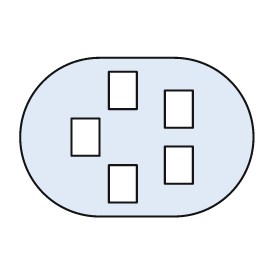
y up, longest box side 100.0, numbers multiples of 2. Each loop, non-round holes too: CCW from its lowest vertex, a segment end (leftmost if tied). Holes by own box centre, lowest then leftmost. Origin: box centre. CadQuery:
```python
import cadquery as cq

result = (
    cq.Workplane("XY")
    .moveTo(-16.0, -34.0)
    .lineTo(16.0, -34.0)
    .threePointArc((50.0, 0.0), (16.0, 34.0))
    .lineTo(-16.0, 34.0)
    .threePointArc((-50.0, 0.0), (-16.0, -34.0))
    .close()
    .moveTo(-12.0, -28.0)
    .lineTo(0.0, -28.0)
    .lineTo(0.0, -12.0)
    .lineTo(-12.0, -12.0)
    .close()
    .moveTo(12.0, -20.0)
    .lineTo(24.0, -20.0)
    .lineTo(24.0, -4.0)
    .lineTo(12.0, -4.0)
    .close()
    .moveTo(-28.0, -8.0)
    .lineTo(-16.0, -8.0)
    .lineTo(-16.0, 8.0)
    .lineTo(-28.0, 8.0)
    .close()
    .moveTo(12.0, 4.0)
    .lineTo(24.0, 4.0)
    .lineTo(24.0, 20.0)
    .lineTo(12.0, 20.0)
    .close()
    .moveTo(-12.0, 12.0)
    .lineTo(0.0, 12.0)
    .lineTo(0.0, 28.0)
    .lineTo(-12.0, 28.0)
    .close()
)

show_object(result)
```